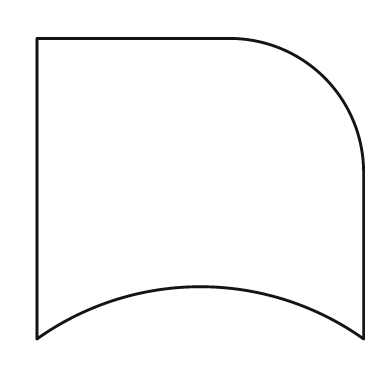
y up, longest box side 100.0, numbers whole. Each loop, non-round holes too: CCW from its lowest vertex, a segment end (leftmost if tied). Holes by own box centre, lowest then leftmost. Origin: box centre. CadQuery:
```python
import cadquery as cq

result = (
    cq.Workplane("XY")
    .moveTo(-50.0, -46.0)
    .threePointArc((0.0, -30.0), (50.0, -46.0))
    .lineTo(50.0, 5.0)
    .threePointArc((38.0, 34.0), (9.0, 46.0))
    .lineTo(-50.0, 46.0)
    .close()
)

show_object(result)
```